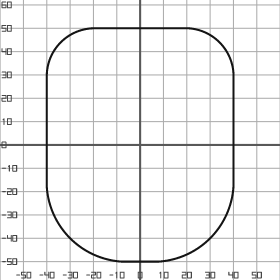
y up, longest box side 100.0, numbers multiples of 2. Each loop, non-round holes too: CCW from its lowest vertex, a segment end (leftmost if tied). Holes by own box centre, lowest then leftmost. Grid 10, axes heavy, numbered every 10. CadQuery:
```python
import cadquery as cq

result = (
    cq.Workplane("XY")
    .moveTo(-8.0, -50.0)
    .lineTo(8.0, -50.0)
    .threePointArc((30.0, -40.0), (40.0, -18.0))
    .lineTo(40.0, 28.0)
    .threePointArc((34.0, 44.0), (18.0, 50.0))
    .lineTo(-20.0, 50.0)
    .threePointArc((-34.0, 44.0), (-40.0, 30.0))
    .lineTo(-40.0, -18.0)
    .threePointArc((-30.0, -40.0), (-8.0, -50.0))
    .close()
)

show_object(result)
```